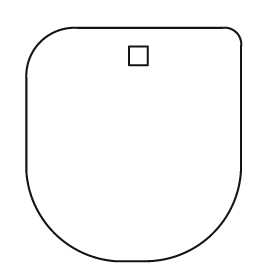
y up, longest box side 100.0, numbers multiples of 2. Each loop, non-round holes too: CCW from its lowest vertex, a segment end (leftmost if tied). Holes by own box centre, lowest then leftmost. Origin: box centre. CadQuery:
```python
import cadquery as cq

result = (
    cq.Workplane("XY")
    .moveTo(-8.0, -50.0)
    .lineTo(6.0, -50.0)
    .threePointArc((34.0, -38.0), (46.0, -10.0))
    .lineTo(46.0, 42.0)
    .threePointArc((44.0, 48.0), (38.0, 50.0))
    .lineTo(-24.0, 50.0)
    .threePointArc((-40.0, 44.0), (-46.0, 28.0))
    .lineTo(-46.0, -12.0)
    .threePointArc((-34.0, -38.0), (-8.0, -50.0))
    .close()
    .moveTo(-2.0, 34.0)
    .lineTo(6.0, 34.0)
    .lineTo(6.0, 42.0)
    .lineTo(-2.0, 42.0)
    .close()
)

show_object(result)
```